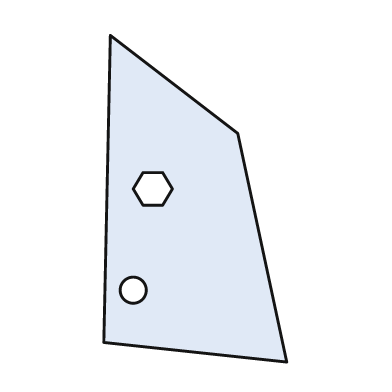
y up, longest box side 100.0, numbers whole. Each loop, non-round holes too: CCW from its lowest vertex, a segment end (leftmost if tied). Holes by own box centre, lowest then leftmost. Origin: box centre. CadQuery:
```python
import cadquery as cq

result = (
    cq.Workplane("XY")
    .moveTo(28.0, -50.0)
    .lineTo(13.0, 20.0)
    .lineTo(-26.0, 50.0)
    .lineTo(-28.0, -44.0)
    .close()
    .moveTo(-19.0, -28.0)
    .circle(4.0)
    .moveTo(-16.0, -2.0)
    .lineTo(-10.0, -2.0)
    .lineTo(-7.0, 3.0)
    .lineTo(-10.0, 8.0)
    .lineTo(-16.0, 8.0)
    .lineTo(-19.0, 3.0)
    .close()
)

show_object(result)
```